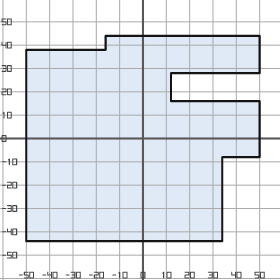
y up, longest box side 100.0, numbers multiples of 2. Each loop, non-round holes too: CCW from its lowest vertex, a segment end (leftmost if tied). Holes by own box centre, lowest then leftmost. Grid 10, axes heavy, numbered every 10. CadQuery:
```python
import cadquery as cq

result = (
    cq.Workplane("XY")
    .moveTo(-50.0, -44.0)
    .lineTo(34.0, -44.0)
    .lineTo(34.0, -8.0)
    .lineTo(50.0, -8.0)
    .lineTo(50.0, 16.0)
    .lineTo(12.0, 16.0)
    .lineTo(12.0, 28.0)
    .lineTo(50.0, 28.0)
    .lineTo(50.0, 44.0)
    .lineTo(-16.0, 44.0)
    .lineTo(-16.0, 38.0)
    .lineTo(-50.0, 38.0)
    .close()
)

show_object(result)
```